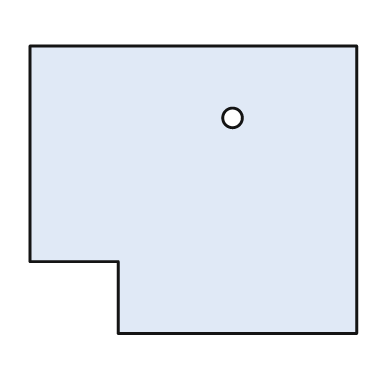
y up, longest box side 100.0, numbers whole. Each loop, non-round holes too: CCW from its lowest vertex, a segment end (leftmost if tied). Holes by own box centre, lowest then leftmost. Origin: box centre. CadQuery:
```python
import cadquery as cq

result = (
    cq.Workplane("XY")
    .moveTo(-23.0, -44.0)
    .lineTo(50.0, -44.0)
    .lineTo(50.0, 44.0)
    .lineTo(-50.0, 44.0)
    .lineTo(-50.0, -22.0)
    .lineTo(-23.0, -22.0)
    .close()
    .moveTo(12.0, 22.0)
    .circle(3.0)
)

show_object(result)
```